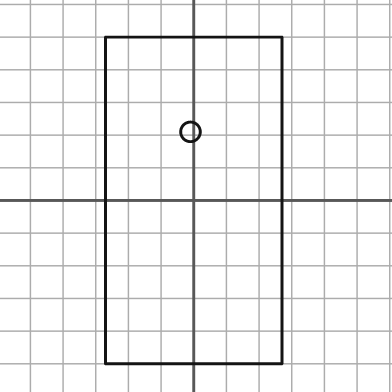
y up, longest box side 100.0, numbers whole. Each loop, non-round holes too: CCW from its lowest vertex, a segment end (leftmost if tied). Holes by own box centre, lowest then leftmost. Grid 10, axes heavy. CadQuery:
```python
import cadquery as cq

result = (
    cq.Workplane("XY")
    .moveTo(-27.0, -50.0)
    .lineTo(27.0, -50.0)
    .lineTo(27.0, 50.0)
    .lineTo(-27.0, 50.0)
    .close()
    .moveTo(-1.0, 21.0)
    .circle(3.0)
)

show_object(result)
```